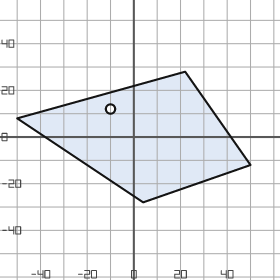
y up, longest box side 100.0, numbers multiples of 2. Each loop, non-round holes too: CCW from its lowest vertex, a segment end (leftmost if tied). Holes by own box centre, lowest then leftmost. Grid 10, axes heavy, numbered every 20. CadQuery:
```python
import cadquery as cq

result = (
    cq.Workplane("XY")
    .moveTo(4.0, -28.0)
    .lineTo(50.0, -12.0)
    .lineTo(22.0, 28.0)
    .lineTo(-50.0, 8.0)
    .close()
    .moveTo(-10.0, 12.0)
    .circle(2.0)
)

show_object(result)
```